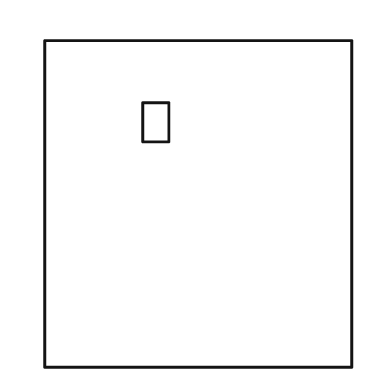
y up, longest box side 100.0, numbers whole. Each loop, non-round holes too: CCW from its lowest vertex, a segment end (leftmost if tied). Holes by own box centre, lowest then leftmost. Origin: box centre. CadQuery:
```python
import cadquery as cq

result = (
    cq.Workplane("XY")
    .moveTo(-47.0, -50.0)
    .lineTo(47.0, -50.0)
    .lineTo(47.0, 50.0)
    .lineTo(-47.0, 50.0)
    .close()
    .moveTo(-17.0, 19.0)
    .lineTo(-9.0, 19.0)
    .lineTo(-9.0, 31.0)
    .lineTo(-17.0, 31.0)
    .close()
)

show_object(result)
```